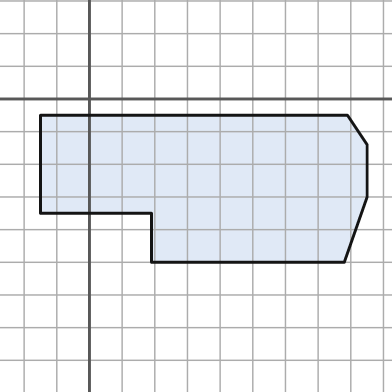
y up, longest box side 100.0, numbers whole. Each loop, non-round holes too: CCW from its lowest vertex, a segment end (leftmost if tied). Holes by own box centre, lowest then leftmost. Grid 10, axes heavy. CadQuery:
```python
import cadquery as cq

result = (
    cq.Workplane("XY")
    .moveTo(19.0, -50.0)
    .lineTo(78.0, -50.0)
    .lineTo(85.0, -30.0)
    .lineTo(85.0, -14.0)
    .lineTo(79.0, -5.0)
    .lineTo(-15.0, -5.0)
    .lineTo(-15.0, -35.0)
    .lineTo(19.0, -35.0)
    .close()
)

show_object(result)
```